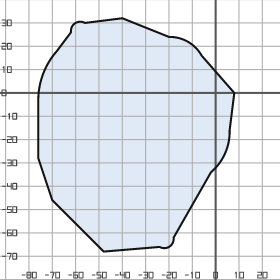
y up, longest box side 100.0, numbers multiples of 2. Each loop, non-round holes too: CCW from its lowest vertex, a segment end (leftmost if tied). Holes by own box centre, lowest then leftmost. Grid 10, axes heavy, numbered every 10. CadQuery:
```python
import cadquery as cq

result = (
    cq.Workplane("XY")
    .moveTo(-48.0, -68.0)
    .lineTo(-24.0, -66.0)
    .threePointArc((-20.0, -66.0), (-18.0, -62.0))
    .lineTo(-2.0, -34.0)
    .threePointArc((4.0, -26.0), (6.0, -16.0))
    .lineTo(8.0, 0.0)
    .lineTo(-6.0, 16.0)
    .threePointArc((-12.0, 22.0), (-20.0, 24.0))
    .lineTo(-40.0, 32.0)
    .lineTo(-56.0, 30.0)
    .threePointArc((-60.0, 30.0), (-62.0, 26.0))
    .lineTo(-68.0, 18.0)
    .threePointArc((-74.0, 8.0), (-76.0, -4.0))
    .lineTo(-76.0, -28.0)
    .lineTo(-70.0, -46.0)
    .close()
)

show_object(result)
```